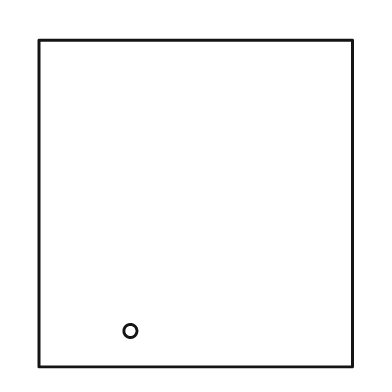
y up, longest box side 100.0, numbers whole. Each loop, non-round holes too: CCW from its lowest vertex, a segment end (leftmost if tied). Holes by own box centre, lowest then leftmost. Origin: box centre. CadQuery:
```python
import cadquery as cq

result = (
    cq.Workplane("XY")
    .moveTo(-48.0, -50.0)
    .lineTo(48.0, -50.0)
    .lineTo(48.0, 50.0)
    .lineTo(-48.0, 50.0)
    .close()
    .moveTo(-20.0, -39.0)
    .circle(2.0)
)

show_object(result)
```